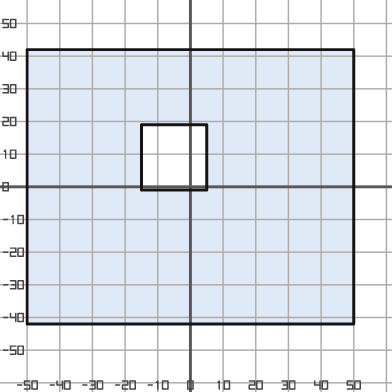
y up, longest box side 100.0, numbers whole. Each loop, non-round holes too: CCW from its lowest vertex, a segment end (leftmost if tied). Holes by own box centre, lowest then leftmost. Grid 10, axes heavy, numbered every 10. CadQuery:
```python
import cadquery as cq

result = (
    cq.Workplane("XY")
    .moveTo(-50.0, -42.0)
    .lineTo(50.0, -42.0)
    .lineTo(50.0, 42.0)
    .lineTo(-50.0, 42.0)
    .close()
    .moveTo(-15.0, -1.0)
    .lineTo(5.0, -1.0)
    .lineTo(5.0, 19.0)
    .lineTo(-15.0, 19.0)
    .close()
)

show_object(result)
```